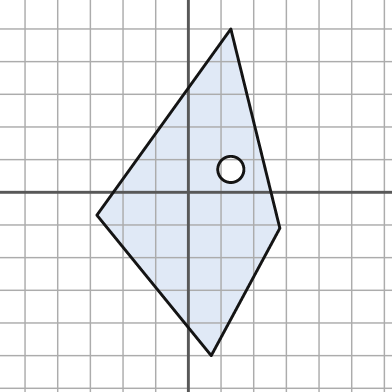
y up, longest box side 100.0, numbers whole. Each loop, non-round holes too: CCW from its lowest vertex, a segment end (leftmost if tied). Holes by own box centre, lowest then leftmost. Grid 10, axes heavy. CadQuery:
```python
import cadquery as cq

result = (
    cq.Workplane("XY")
    .moveTo(7.0, -50.0)
    .lineTo(28.0, -11.0)
    .lineTo(13.0, 50.0)
    .lineTo(-28.0, -7.0)
    .close()
    .moveTo(13.0, 7.0)
    .circle(4.0)
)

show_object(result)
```